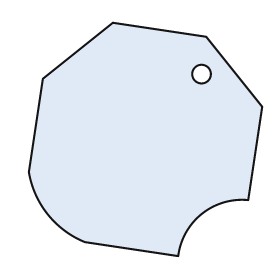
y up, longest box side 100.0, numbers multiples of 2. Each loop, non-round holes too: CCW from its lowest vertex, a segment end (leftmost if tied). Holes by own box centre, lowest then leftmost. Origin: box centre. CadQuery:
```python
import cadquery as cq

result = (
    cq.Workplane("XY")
    .moveTo(14.0, -50.0)
    .threePointArc((24.0, -32.0), (44.0, -26.0))
    .lineTo(50.0, 14.0)
    .lineTo(26.0, 44.0)
    .lineTo(-14.0, 50.0)
    .lineTo(-44.0, 26.0)
    .lineTo(-50.0, -14.0)
    .threePointArc((-42.0, -32.0), (-26.0, -44.0))
    .close()
    .moveTo(24.0, 28.0)
    .circle(4.0)
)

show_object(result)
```